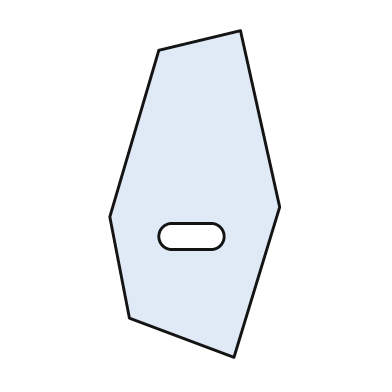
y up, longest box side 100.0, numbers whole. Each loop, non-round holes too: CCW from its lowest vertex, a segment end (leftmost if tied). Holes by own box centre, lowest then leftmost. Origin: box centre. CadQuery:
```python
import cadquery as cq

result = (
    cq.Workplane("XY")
    .moveTo(12.0, -50.0)
    .lineTo(26.0, -4.0)
    .lineTo(14.0, 50.0)
    .lineTo(-11.0, 44.0)
    .lineTo(-26.0, -7.0)
    .lineTo(-20.0, -38.0)
    .close()
    .moveTo(-7.0, -17.0)
    .lineTo(5.0, -17.0)
    .threePointArc((9.0, -13.0), (5.0, -9.0))
    .lineTo(-7.0, -9.0)
    .threePointArc((-11.0, -13.0), (-7.0, -17.0))
    .close()
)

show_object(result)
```